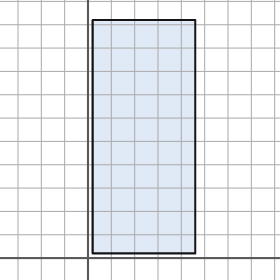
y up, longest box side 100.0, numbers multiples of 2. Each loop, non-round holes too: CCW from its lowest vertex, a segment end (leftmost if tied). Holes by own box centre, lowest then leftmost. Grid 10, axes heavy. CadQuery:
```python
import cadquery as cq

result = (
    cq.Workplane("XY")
    .moveTo(2.0, 2.0)
    .lineTo(46.0, 2.0)
    .lineTo(46.0, 102.0)
    .lineTo(2.0, 102.0)
    .close()
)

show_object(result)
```